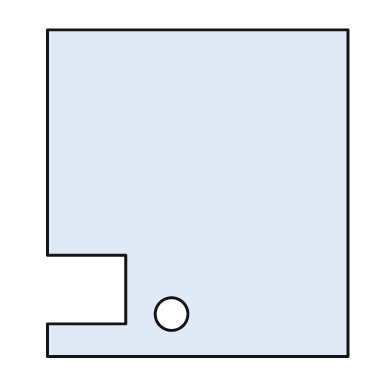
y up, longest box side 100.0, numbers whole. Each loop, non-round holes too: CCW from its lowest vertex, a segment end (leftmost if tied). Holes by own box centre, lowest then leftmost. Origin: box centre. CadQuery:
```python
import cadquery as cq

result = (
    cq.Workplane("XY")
    .moveTo(-46.0, -50.0)
    .lineTo(46.0, -50.0)
    .lineTo(46.0, 50.0)
    .lineTo(-46.0, 50.0)
    .lineTo(-46.0, -19.0)
    .lineTo(-22.0, -19.0)
    .lineTo(-22.0, -40.0)
    .lineTo(-46.0, -40.0)
    .close()
    .moveTo(-8.0, -37.0)
    .circle(5.0)
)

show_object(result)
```